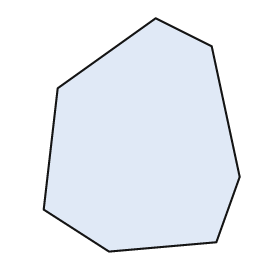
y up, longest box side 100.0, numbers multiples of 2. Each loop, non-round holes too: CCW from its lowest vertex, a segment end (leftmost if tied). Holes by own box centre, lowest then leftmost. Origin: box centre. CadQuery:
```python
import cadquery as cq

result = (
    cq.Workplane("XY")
    .moveTo(-14.0, -50.0)
    .lineTo(32.0, -46.0)
    .lineTo(42.0, -18.0)
    .lineTo(30.0, 38.0)
    .lineTo(6.0, 50.0)
    .lineTo(-36.0, 20.0)
    .lineTo(-42.0, -32.0)
    .close()
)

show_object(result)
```